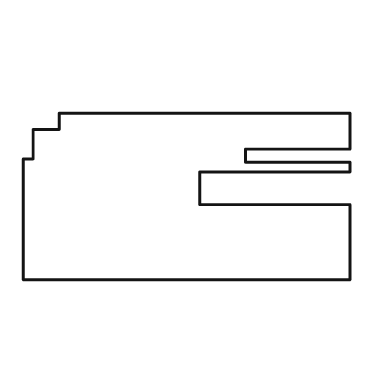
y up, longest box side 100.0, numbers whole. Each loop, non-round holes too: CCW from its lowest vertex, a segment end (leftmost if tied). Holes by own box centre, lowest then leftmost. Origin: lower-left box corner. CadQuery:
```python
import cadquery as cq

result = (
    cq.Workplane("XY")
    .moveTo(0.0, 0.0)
    .lineTo(100.0, 0.0)
    .lineTo(100.0, 23.0)
    .lineTo(54.0, 23.0)
    .lineTo(54.0, 33.0)
    .lineTo(100.0, 33.0)
    .lineTo(100.0, 36.0)
    .lineTo(68.0, 36.0)
    .lineTo(68.0, 40.0)
    .lineTo(100.0, 40.0)
    .lineTo(100.0, 51.0)
    .lineTo(11.0, 51.0)
    .lineTo(11.0, 46.0)
    .lineTo(3.0, 46.0)
    .lineTo(3.0, 37.0)
    .lineTo(0.0, 37.0)
    .close()
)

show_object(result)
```